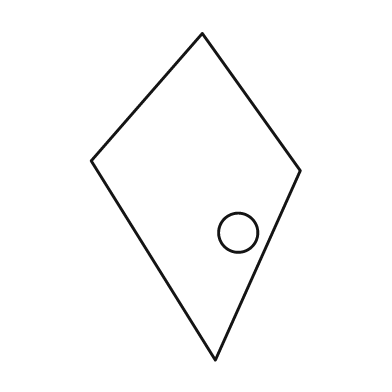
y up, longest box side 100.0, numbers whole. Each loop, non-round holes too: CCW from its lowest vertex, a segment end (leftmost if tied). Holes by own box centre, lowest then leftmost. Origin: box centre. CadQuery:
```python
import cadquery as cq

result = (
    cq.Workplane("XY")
    .moveTo(6.0, -50.0)
    .lineTo(32.0, 8.0)
    .lineTo(2.0, 50.0)
    .lineTo(-32.0, 11.0)
    .close()
    .moveTo(13.0, -11.0)
    .circle(6.0)
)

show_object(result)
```